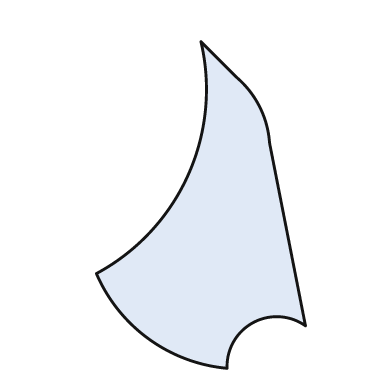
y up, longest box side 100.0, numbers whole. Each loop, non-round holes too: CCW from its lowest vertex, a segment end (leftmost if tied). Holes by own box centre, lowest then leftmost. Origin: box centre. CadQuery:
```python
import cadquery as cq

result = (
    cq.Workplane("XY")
    .moveTo(8.0, -50.0)
    .threePointArc((16.0, -36.0), (32.0, -37.0))
    .lineTo(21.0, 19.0)
    .threePointArc((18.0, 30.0), (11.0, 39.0))
    .lineTo(0.0, 50.0)
    .threePointArc((-4.0, 9.0), (-32.0, -21.0))
    .threePointArc((-16.0, -41.0), (8.0, -50.0))
    .close()
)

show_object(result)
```